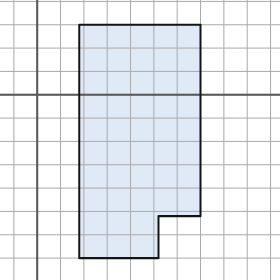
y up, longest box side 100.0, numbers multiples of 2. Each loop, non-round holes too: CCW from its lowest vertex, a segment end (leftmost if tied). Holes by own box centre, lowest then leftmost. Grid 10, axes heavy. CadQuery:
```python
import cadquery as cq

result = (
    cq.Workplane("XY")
    .moveTo(18.0, -70.0)
    .lineTo(52.0, -70.0)
    .lineTo(52.0, -52.0)
    .lineTo(70.0, -52.0)
    .lineTo(70.0, 30.0)
    .lineTo(18.0, 30.0)
    .close()
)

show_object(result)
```